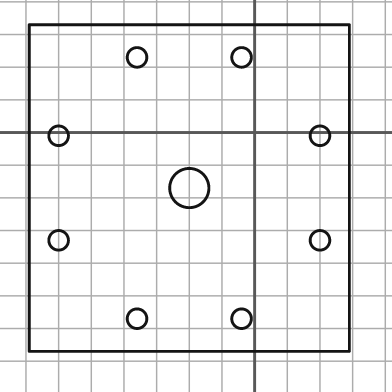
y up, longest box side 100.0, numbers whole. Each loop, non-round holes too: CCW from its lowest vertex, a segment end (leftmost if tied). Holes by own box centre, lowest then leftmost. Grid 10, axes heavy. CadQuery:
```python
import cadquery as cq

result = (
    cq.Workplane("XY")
    .moveTo(-69.0, -67.0)
    .lineTo(29.0, -67.0)
    .lineTo(29.0, 33.0)
    .lineTo(-69.0, 33.0)
    .close()
    .moveTo(-36.0, -57.0)
    .circle(3.0)
    .moveTo(-4.0, -57.0)
    .circle(3.0)
    .moveTo(-60.0, -33.0)
    .circle(3.0)
    .moveTo(20.0, -33.0)
    .circle(3.0)
    .moveTo(-20.0, -17.0)
    .circle(6.0)
    .moveTo(-60.0, -1.0)
    .circle(3.0)
    .moveTo(20.0, -1.0)
    .circle(3.0)
    .moveTo(-36.0, 23.0)
    .circle(3.0)
    .moveTo(-4.0, 23.0)
    .circle(3.0)
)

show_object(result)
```